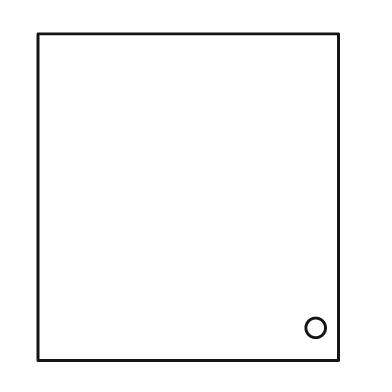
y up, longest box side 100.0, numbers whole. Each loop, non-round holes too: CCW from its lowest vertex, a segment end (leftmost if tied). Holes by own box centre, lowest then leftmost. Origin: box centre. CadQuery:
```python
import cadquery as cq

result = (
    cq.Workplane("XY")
    .moveTo(-46.0, -50.0)
    .lineTo(46.0, -50.0)
    .lineTo(46.0, 50.0)
    .lineTo(-46.0, 50.0)
    .close()
    .moveTo(39.0, -40.0)
    .circle(3.0)
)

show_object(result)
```